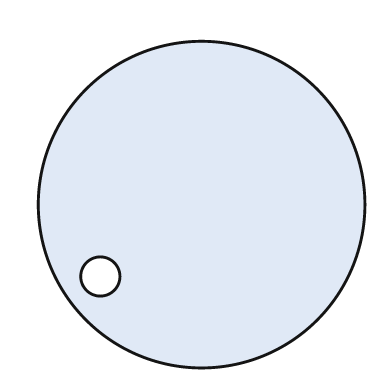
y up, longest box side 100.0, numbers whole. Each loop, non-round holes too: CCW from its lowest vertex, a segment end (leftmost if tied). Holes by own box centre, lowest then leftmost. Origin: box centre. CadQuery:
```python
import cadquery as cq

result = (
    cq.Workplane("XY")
    .moveTo(0.0, 0.0)
    .circle(50.0)
    .moveTo(-31.0, -22.0)
    .circle(6.0)
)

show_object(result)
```